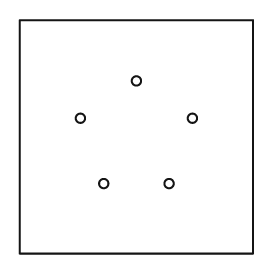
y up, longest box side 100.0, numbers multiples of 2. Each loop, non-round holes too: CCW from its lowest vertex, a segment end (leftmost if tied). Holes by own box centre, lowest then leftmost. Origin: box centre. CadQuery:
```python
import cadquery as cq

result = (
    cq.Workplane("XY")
    .moveTo(-50.0, -50.0)
    .lineTo(50.0, -50.0)
    .lineTo(50.0, 50.0)
    .lineTo(-50.0, 50.0)
    .close()
    .moveTo(-14.0, -20.0)
    .circle(2.0)
    .moveTo(14.0, -20.0)
    .circle(2.0)
    .moveTo(-24.0, 8.0)
    .circle(2.0)
    .moveTo(24.0, 8.0)
    .circle(2.0)
    .moveTo(0.0, 24.0)
    .circle(2.0)
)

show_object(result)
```